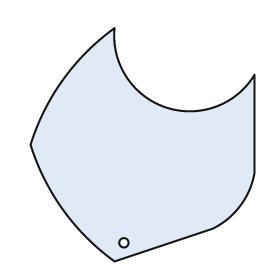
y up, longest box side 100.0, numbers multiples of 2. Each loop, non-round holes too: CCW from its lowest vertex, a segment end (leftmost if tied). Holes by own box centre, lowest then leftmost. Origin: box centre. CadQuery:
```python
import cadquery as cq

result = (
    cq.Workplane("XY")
    .moveTo(-12.0, -50.0)
    .lineTo(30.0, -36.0)
    .threePointArc((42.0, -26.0), (48.0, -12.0))
    .lineTo(48.0, 30.0)
    .threePointArc((10.0, 16.0), (-12.0, 50.0))
    .threePointArc((-34.0, 28.0), (-48.0, 0.0))
    .threePointArc((-34.0, -28.0), (-12.0, -50.0))
    .close()
    .moveTo(-8.0, -42.0)
    .circle(2.0)
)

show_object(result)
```